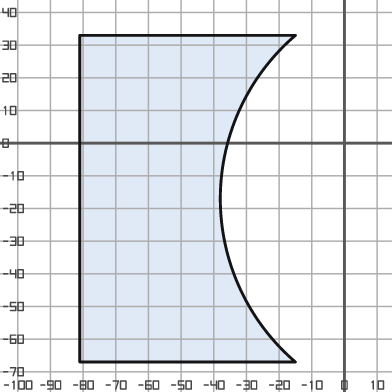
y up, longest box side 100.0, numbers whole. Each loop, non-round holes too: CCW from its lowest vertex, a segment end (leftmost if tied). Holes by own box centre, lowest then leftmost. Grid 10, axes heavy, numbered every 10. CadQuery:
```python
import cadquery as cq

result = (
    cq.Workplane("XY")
    .moveTo(-81.0, -67.0)
    .lineTo(-15.0, -67.0)
    .threePointArc((-38.0, -17.0), (-15.0, 33.0))
    .lineTo(-81.0, 33.0)
    .close()
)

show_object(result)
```